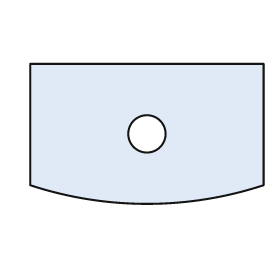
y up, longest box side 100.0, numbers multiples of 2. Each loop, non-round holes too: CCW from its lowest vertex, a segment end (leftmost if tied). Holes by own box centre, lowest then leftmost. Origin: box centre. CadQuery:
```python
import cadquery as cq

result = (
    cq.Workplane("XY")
    .moveTo(-50.0, -22.0)
    .threePointArc((0.0, -30.0), (50.0, -22.0))
    .lineTo(50.0, 30.0)
    .lineTo(-50.0, 30.0)
    .close()
    .moveTo(0.0, 0.0)
    .circle(8.0)
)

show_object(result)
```